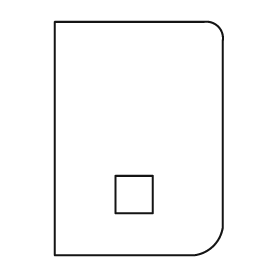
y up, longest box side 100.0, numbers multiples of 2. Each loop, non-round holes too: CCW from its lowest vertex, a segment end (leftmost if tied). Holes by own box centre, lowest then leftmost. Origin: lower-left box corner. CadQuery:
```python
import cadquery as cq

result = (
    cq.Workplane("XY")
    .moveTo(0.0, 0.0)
    .lineTo(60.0, 0.0)
    .threePointArc((68.0, 4.0), (72.0, 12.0))
    .lineTo(72.0, 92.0)
    .threePointArc((70.0, 98.0), (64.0, 100.0))
    .lineTo(0.0, 100.0)
    .close()
    .moveTo(26.0, 18.0)
    .lineTo(42.0, 18.0)
    .lineTo(42.0, 34.0)
    .lineTo(26.0, 34.0)
    .close()
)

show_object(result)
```